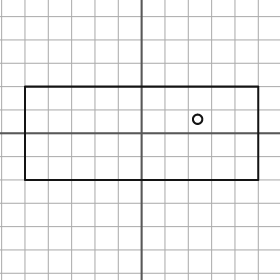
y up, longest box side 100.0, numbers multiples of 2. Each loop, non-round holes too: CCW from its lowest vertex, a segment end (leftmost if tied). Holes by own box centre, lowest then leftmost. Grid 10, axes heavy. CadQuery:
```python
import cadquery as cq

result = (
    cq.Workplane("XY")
    .moveTo(-50.0, -20.0)
    .lineTo(50.0, -20.0)
    .lineTo(50.0, 20.0)
    .lineTo(-50.0, 20.0)
    .close()
    .moveTo(24.0, 6.0)
    .circle(2.0)
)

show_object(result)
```